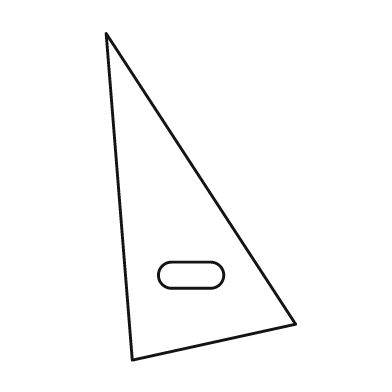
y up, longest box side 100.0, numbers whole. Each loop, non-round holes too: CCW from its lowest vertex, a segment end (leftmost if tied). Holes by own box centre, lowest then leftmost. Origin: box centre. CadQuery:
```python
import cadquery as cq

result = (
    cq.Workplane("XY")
    .moveTo(-21.0, -50.0)
    .lineTo(29.0, -39.0)
    .lineTo(-29.0, 50.0)
    .close()
    .moveTo(-9.0, -28.0)
    .lineTo(3.0, -28.0)
    .threePointArc((7.0, -24.0), (3.0, -20.0))
    .lineTo(-9.0, -20.0)
    .threePointArc((-13.0, -24.0), (-9.0, -28.0))
    .close()
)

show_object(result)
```